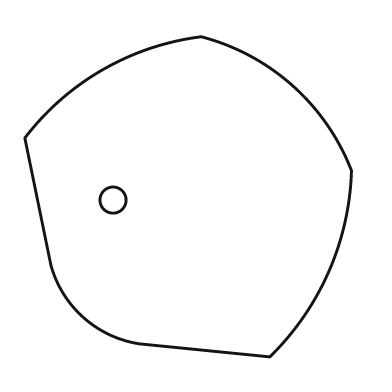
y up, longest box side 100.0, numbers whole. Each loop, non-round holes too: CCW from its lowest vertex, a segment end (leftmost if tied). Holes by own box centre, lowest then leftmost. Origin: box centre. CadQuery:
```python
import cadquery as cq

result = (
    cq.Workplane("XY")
    .moveTo(25.0, -49.0)
    .threePointArc((43.0, -23.0), (50.0, 8.0))
    .threePointArc((32.0, 34.0), (4.0, 49.0))
    .threePointArc((-26.0, 39.0), (-50.0, 18.0))
    .lineTo(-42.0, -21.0)
    .threePointArc((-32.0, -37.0), (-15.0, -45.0))
    .close()
    .moveTo(-23.0, -1.0)
    .circle(4.0)
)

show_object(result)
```